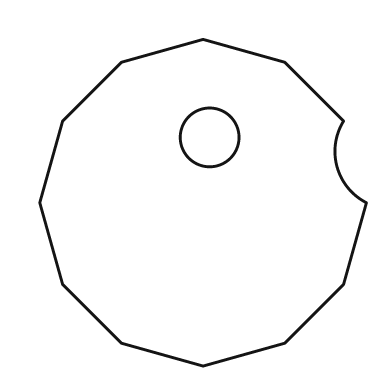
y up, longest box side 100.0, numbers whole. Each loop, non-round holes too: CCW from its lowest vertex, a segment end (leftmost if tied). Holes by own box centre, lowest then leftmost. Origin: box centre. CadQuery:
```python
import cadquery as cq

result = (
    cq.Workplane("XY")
    .moveTo(0.0, -50.0)
    .lineTo(25.0, -43.0)
    .lineTo(43.0, -25.0)
    .lineTo(50.0, 0.0)
    .threePointArc((41.0, 11.0), (43.0, 25.0))
    .lineTo(25.0, 43.0)
    .lineTo(0.0, 50.0)
    .lineTo(-25.0, 43.0)
    .lineTo(-43.0, 25.0)
    .lineTo(-50.0, 0.0)
    .lineTo(-43.0, -25.0)
    .lineTo(-25.0, -43.0)
    .close()
    .moveTo(2.0, 20.0)
    .circle(9.0)
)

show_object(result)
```